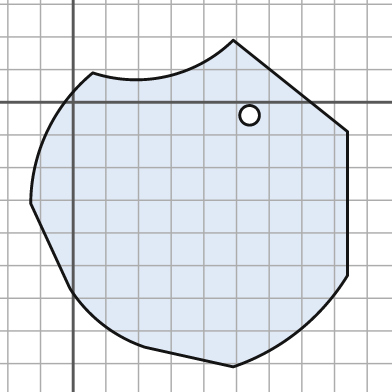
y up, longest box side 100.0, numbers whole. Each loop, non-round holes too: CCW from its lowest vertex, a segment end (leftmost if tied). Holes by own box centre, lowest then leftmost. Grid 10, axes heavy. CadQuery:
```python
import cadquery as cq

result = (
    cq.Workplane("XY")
    .moveTo(49.0, -81.0)
    .threePointArc((69.0, -70.0), (84.0, -53.0))
    .lineTo(84.0, -9.0)
    .lineTo(49.0, 19.0)
    .threePointArc((29.0, 8.0), (6.0, 9.0))
    .threePointArc((-8.0, -9.0), (-13.0, -31.0))
    .lineTo(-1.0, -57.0)
    .threePointArc((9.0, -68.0), (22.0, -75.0))
    .close()
    .moveTo(54.0, -4.0)
    .circle(3.0)
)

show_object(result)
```